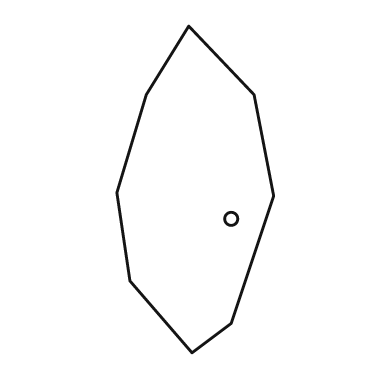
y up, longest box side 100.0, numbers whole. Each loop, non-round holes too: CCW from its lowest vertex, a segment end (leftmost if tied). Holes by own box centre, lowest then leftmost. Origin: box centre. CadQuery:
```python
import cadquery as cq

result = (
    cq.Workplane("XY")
    .moveTo(-1.0, -50.0)
    .lineTo(11.0, -41.0)
    .lineTo(24.0, -2.0)
    .lineTo(18.0, 29.0)
    .lineTo(-2.0, 50.0)
    .lineTo(-15.0, 29.0)
    .lineTo(-24.0, -1.0)
    .lineTo(-20.0, -28.0)
    .close()
    .moveTo(11.0, -9.0)
    .circle(2.0)
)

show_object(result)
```